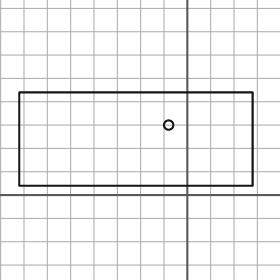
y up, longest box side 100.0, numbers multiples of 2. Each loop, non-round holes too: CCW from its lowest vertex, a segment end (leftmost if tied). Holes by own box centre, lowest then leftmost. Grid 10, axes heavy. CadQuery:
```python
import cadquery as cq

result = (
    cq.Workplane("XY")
    .moveTo(-72.0, 4.0)
    .lineTo(28.0, 4.0)
    .lineTo(28.0, 44.0)
    .lineTo(-72.0, 44.0)
    .close()
    .moveTo(-8.0, 30.0)
    .circle(2.0)
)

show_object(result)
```